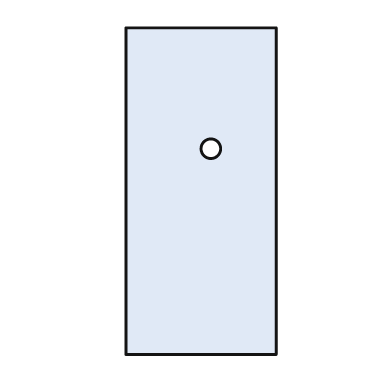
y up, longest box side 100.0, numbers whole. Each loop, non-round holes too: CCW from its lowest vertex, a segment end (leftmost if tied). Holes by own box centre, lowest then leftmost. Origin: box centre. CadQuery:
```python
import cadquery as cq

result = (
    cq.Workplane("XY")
    .moveTo(-23.0, -50.0)
    .lineTo(23.0, -50.0)
    .lineTo(23.0, 50.0)
    .lineTo(-23.0, 50.0)
    .close()
    .moveTo(3.0, 13.0)
    .circle(3.0)
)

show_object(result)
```